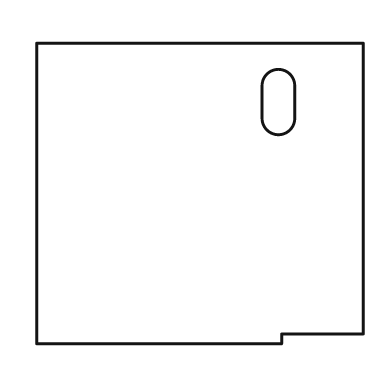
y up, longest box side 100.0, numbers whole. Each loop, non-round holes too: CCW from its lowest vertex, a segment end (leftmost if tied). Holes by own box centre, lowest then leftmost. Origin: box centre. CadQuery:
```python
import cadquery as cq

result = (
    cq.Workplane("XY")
    .moveTo(-50.0, -46.0)
    .lineTo(25.0, -46.0)
    .lineTo(25.0, -43.0)
    .lineTo(50.0, -43.0)
    .lineTo(50.0, 46.0)
    .lineTo(-50.0, 46.0)
    .close()
    .moveTo(19.0, 23.0)
    .threePointArc((24.0, 18.0), (29.0, 23.0))
    .lineTo(29.0, 33.0)
    .threePointArc((24.0, 38.0), (19.0, 33.0))
    .close()
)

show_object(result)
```